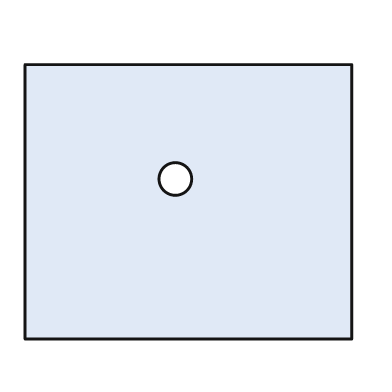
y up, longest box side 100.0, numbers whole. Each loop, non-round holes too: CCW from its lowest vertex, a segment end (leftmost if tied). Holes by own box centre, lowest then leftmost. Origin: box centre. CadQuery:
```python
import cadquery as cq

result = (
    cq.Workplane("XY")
    .moveTo(-50.0, -42.0)
    .lineTo(50.0, -42.0)
    .lineTo(50.0, 42.0)
    .lineTo(-50.0, 42.0)
    .close()
    .moveTo(-4.0, 7.0)
    .circle(5.0)
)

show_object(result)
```